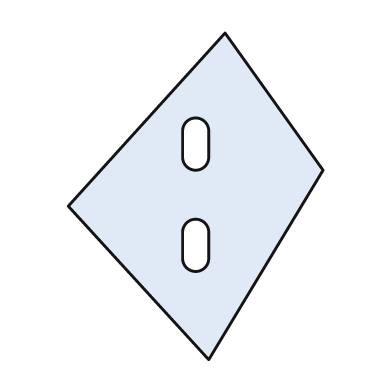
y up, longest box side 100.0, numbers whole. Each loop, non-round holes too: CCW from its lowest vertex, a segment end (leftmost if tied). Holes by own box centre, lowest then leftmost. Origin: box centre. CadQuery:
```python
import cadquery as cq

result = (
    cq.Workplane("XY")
    .moveTo(4.0, -50.0)
    .lineTo(39.0, 8.0)
    .lineTo(9.0, 50.0)
    .lineTo(-39.0, -3.0)
    .close()
    .moveTo(-4.0, -19.0)
    .threePointArc((0.0, -23.0), (4.0, -19.0))
    .lineTo(4.0, -11.0)
    .threePointArc((0.0, -7.0), (-4.0, -11.0))
    .close()
    .moveTo(-4.0, 12.0)
    .threePointArc((0.0, 8.0), (4.0, 12.0))
    .lineTo(4.0, 20.0)
    .threePointArc((0.0, 24.0), (-4.0, 20.0))
    .close()
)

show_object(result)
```